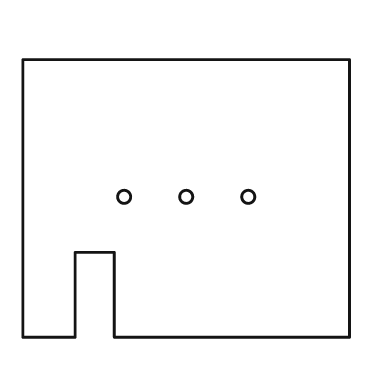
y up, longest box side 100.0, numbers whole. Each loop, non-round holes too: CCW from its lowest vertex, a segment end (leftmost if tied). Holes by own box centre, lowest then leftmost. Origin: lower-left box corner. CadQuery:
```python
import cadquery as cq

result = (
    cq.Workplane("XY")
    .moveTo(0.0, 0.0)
    .lineTo(16.0, 0.0)
    .lineTo(16.0, 26.0)
    .lineTo(28.0, 26.0)
    .lineTo(28.0, 0.0)
    .lineTo(100.0, 0.0)
    .lineTo(100.0, 85.0)
    .lineTo(0.0, 85.0)
    .close()
    .moveTo(31.0, 43.0)
    .circle(2.0)
    .moveTo(50.0, 43.0)
    .circle(2.0)
    .moveTo(69.0, 43.0)
    .circle(2.0)
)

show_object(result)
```